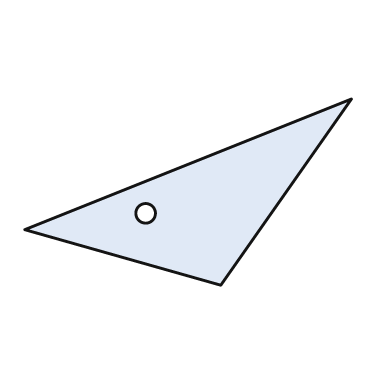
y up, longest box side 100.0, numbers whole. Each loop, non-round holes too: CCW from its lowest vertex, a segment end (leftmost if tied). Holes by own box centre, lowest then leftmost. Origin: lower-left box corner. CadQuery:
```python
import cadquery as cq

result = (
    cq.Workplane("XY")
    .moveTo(60.0, 0.0)
    .lineTo(100.0, 57.0)
    .lineTo(0.0, 17.0)
    .close()
    .moveTo(37.0, 22.0)
    .circle(3.0)
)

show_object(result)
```